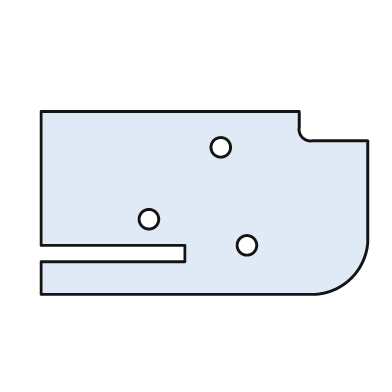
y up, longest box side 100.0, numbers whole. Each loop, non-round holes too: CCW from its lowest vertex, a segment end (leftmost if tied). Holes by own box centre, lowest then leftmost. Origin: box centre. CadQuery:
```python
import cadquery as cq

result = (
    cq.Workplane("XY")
    .moveTo(-50.0, -28.0)
    .lineTo(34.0, -28.0)
    .threePointArc((45.0, -23.0), (50.0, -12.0))
    .lineTo(50.0, 19.0)
    .lineTo(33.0, 19.0)
    .threePointArc((30.0, 20.0), (29.0, 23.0))
    .lineTo(29.0, 28.0)
    .lineTo(-50.0, 28.0)
    .lineTo(-50.0, -13.0)
    .lineTo(-6.0, -13.0)
    .lineTo(-6.0, -18.0)
    .lineTo(-50.0, -18.0)
    .close()
    .moveTo(13.0, -13.0)
    .circle(3.0)
    .moveTo(-17.0, -5.0)
    .circle(3.0)
    .moveTo(5.0, 17.0)
    .circle(3.0)
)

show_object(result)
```